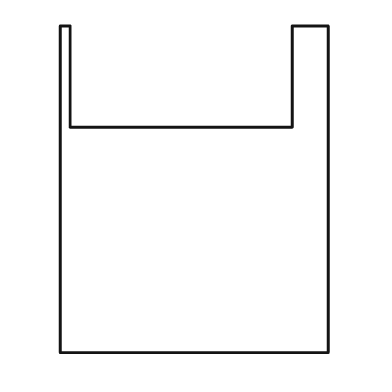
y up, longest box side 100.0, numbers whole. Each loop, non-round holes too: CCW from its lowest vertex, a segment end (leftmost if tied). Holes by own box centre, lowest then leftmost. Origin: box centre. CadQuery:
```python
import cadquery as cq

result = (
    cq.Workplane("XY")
    .moveTo(-41.0, -50.0)
    .lineTo(41.0, -50.0)
    .lineTo(41.0, 50.0)
    .lineTo(30.0, 50.0)
    .lineTo(30.0, 19.0)
    .lineTo(-38.0, 19.0)
    .lineTo(-38.0, 50.0)
    .lineTo(-41.0, 50.0)
    .close()
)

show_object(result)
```